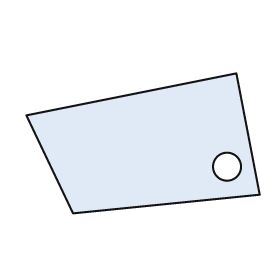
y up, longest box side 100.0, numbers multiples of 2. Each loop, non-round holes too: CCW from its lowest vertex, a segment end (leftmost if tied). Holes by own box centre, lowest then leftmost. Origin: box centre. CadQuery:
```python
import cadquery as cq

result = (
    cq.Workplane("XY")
    .moveTo(-30.0, -30.0)
    .lineTo(50.0, -22.0)
    .lineTo(40.0, 30.0)
    .lineTo(-50.0, 12.0)
    .close()
    .moveTo(36.0, -10.0)
    .circle(6.0)
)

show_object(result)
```